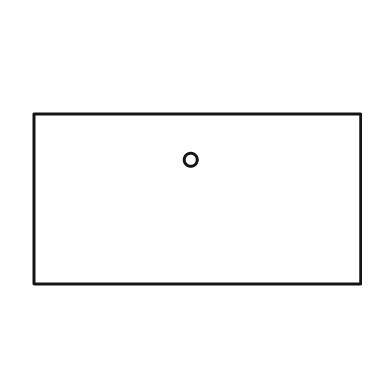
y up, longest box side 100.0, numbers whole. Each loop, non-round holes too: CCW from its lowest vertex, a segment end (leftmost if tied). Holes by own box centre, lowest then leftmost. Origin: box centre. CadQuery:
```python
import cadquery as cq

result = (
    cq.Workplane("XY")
    .moveTo(-50.0, -26.0)
    .lineTo(50.0, -26.0)
    .lineTo(50.0, 26.0)
    .lineTo(-50.0, 26.0)
    .close()
    .moveTo(-2.0, 12.0)
    .circle(2.0)
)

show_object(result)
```